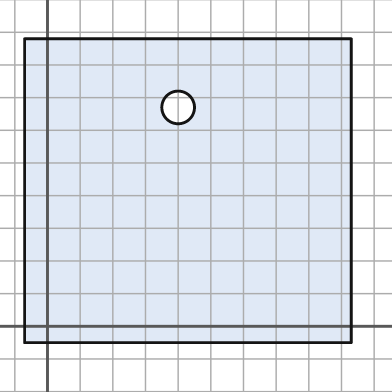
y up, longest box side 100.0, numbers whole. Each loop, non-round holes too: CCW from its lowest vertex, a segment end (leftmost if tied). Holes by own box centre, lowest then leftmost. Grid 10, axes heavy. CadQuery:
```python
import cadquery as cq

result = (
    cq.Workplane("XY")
    .moveTo(-7.0, -5.0)
    .lineTo(93.0, -5.0)
    .lineTo(93.0, 88.0)
    .lineTo(-7.0, 88.0)
    .close()
    .moveTo(40.0, 67.0)
    .circle(5.0)
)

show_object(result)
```